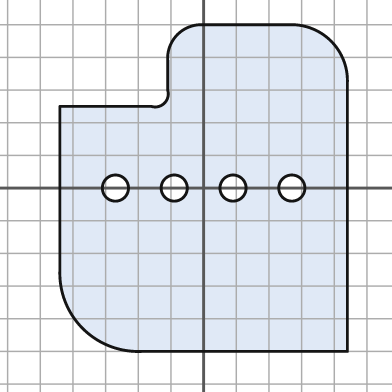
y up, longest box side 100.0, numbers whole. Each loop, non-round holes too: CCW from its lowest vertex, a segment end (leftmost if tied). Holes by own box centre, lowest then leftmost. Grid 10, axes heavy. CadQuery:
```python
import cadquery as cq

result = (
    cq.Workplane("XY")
    .moveTo(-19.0, -50.0)
    .lineTo(44.0, -50.0)
    .lineTo(44.0, 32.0)
    .threePointArc((39.0, 45.0), (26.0, 50.0))
    .lineTo(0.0, 50.0)
    .threePointArc((-8.0, 47.0), (-11.0, 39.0))
    .lineTo(-11.0, 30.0)
    .threePointArc((-12.0, 26.0), (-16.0, 25.0))
    .lineTo(-44.0, 25.0)
    .lineTo(-44.0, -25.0)
    .threePointArc((-37.0, -43.0), (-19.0, -50.0))
    .close()
    .moveTo(-27.0, 0.0)
    .circle(4.0)
    .moveTo(-9.0, 0.0)
    .circle(4.0)
    .moveTo(9.0, 0.0)
    .circle(4.0)
    .moveTo(27.0, 0.0)
    .circle(4.0)
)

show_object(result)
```